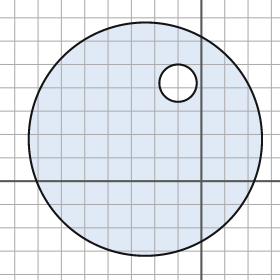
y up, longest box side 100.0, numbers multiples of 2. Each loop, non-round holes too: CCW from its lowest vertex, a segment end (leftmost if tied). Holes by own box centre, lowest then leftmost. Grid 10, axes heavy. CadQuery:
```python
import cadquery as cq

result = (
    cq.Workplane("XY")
    .moveTo(-24.0, 18.0)
    .circle(50.0)
    .moveTo(-10.0, 42.0)
    .circle(8.0)
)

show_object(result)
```